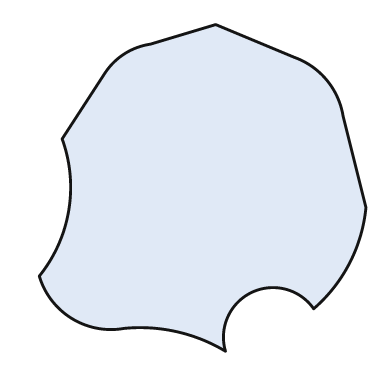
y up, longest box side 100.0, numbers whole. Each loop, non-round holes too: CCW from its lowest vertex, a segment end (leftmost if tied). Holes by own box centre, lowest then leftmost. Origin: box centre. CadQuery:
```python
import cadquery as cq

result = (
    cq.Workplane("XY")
    .moveTo(7.0, -50.0)
    .threePointArc((15.0, -32.0), (34.0, -37.0))
    .threePointArc((45.0, -23.0), (50.0, -6.0))
    .lineTo(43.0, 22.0)
    .threePointArc((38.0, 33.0), (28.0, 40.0))
    .lineTo(4.0, 50.0)
    .lineTo(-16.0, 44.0)
    .threePointArc((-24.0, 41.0), (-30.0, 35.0))
    .lineTo(-43.0, 15.0)
    .threePointArc((-41.0, -7.0), (-50.0, -27.0))
    .threePointArc((-40.0, -40.0), (-24.0, -43.0))
    .threePointArc((-8.0, -44.0), (7.0, -50.0))
    .close()
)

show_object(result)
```